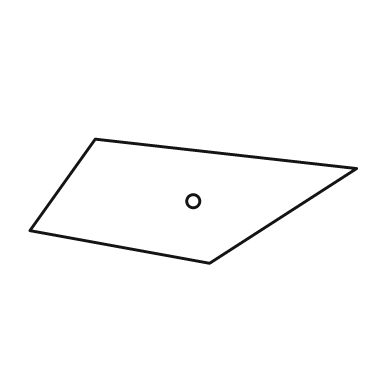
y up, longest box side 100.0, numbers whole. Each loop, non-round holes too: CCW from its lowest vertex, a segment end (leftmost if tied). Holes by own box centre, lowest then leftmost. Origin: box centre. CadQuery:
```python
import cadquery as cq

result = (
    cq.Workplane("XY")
    .moveTo(5.0, -19.0)
    .lineTo(50.0, 10.0)
    .lineTo(-30.0, 19.0)
    .lineTo(-50.0, -9.0)
    .close()
    .moveTo(0.0, 0.0)
    .circle(2.0)
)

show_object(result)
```